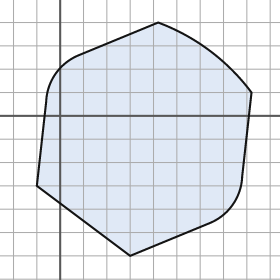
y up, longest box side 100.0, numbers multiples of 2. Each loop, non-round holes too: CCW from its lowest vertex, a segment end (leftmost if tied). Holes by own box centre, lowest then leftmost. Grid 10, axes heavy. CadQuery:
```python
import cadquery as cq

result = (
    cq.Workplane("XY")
    .moveTo(30.0, -60.0)
    .lineTo(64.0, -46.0)
    .threePointArc((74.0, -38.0), (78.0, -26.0))
    .lineTo(82.0, 10.0)
    .threePointArc((64.0, 28.0), (42.0, 40.0))
    .lineTo(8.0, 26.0)
    .threePointArc((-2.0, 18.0), (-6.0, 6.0))
    .lineTo(-10.0, -30.0)
    .close()
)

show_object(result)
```